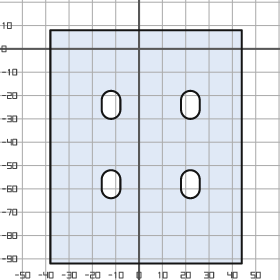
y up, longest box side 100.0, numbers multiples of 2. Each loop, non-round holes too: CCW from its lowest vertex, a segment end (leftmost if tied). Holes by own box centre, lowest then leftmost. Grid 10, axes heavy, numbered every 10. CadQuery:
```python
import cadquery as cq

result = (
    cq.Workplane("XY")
    .moveTo(-38.0, -92.0)
    .lineTo(44.0, -92.0)
    .lineTo(44.0, 8.0)
    .lineTo(-38.0, 8.0)
    .close()
    .moveTo(-16.0, -60.0)
    .threePointArc((-12.0, -64.0), (-8.0, -60.0))
    .lineTo(-8.0, -56.0)
    .threePointArc((-12.0, -52.0), (-16.0, -56.0))
    .close()
    .moveTo(18.0, -60.0)
    .threePointArc((22.0, -64.0), (26.0, -60.0))
    .lineTo(26.0, -56.0)
    .threePointArc((22.0, -52.0), (18.0, -56.0))
    .close()
    .moveTo(-16.0, -26.0)
    .threePointArc((-12.0, -30.0), (-8.0, -26.0))
    .lineTo(-8.0, -22.0)
    .threePointArc((-12.0, -18.0), (-16.0, -22.0))
    .close()
    .moveTo(18.0, -26.0)
    .threePointArc((22.0, -30.0), (26.0, -26.0))
    .lineTo(26.0, -22.0)
    .threePointArc((22.0, -18.0), (18.0, -22.0))
    .close()
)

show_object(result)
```